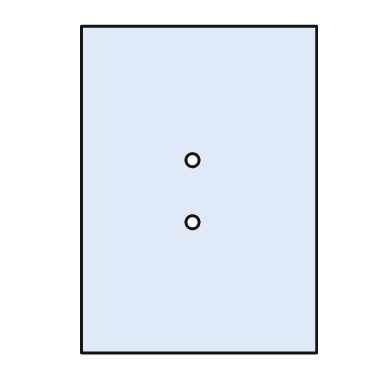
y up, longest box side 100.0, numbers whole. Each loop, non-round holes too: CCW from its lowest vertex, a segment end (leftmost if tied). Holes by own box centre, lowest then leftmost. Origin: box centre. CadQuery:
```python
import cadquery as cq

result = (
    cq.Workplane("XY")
    .moveTo(-36.0, -50.0)
    .lineTo(36.0, -50.0)
    .lineTo(36.0, 50.0)
    .lineTo(-36.0, 50.0)
    .close()
    .moveTo(-2.0, -10.0)
    .circle(2.0)
    .moveTo(-2.0, 9.0)
    .circle(2.0)
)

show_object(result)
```